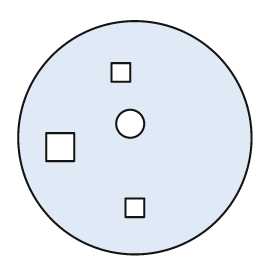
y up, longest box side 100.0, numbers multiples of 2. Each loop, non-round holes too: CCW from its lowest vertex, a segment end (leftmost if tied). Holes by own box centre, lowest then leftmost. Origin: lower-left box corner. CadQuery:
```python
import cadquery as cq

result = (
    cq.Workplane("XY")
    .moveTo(50.0, 50.0)
    .circle(50.0)
    .moveTo(46.0, 16.0)
    .lineTo(54.0, 16.0)
    .lineTo(54.0, 24.0)
    .lineTo(46.0, 24.0)
    .close()
    .moveTo(12.0, 40.0)
    .lineTo(24.0, 40.0)
    .lineTo(24.0, 52.0)
    .lineTo(12.0, 52.0)
    .close()
    .moveTo(48.0, 56.0)
    .circle(6.0)
    .moveTo(40.0, 74.0)
    .lineTo(48.0, 74.0)
    .lineTo(48.0, 82.0)
    .lineTo(40.0, 82.0)
    .close()
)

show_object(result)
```